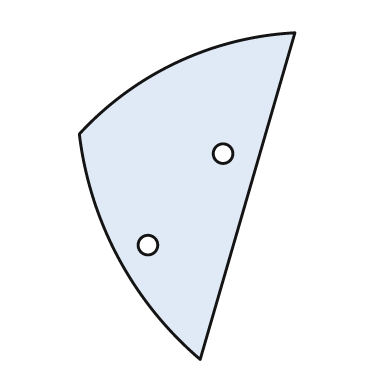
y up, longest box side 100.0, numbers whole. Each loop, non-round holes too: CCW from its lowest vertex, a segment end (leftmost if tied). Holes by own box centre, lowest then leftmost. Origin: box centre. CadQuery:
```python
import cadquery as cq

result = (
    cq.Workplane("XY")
    .moveTo(4.0, -50.0)
    .lineTo(33.0, 50.0)
    .threePointArc((-3.0, 41.0), (-33.0, 19.0))
    .threePointArc((-21.0, -19.0), (4.0, -50.0))
    .close()
    .moveTo(-12.0, -15.0)
    .circle(3.0)
    .moveTo(11.0, 13.0)
    .circle(3.0)
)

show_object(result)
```